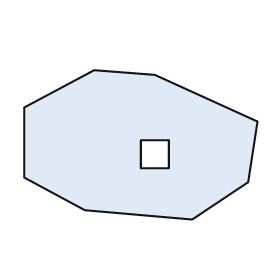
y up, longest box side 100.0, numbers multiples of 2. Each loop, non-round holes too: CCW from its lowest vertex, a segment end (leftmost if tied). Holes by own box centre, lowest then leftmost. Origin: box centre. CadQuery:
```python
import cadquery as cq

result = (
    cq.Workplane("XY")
    .moveTo(22.0, -32.0)
    .lineTo(46.0, -16.0)
    .lineTo(50.0, 10.0)
    .lineTo(6.0, 30.0)
    .lineTo(-20.0, 32.0)
    .lineTo(-50.0, 16.0)
    .lineTo(-50.0, -14.0)
    .lineTo(-24.0, -28.0)
    .close()
    .moveTo(0.0, -10.0)
    .lineTo(12.0, -10.0)
    .lineTo(12.0, 2.0)
    .lineTo(0.0, 2.0)
    .close()
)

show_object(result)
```